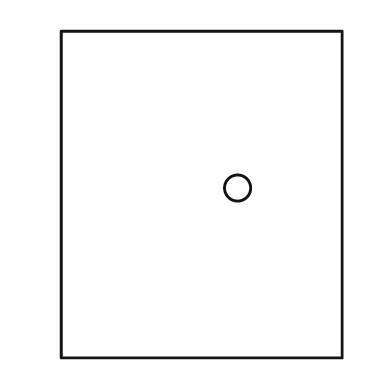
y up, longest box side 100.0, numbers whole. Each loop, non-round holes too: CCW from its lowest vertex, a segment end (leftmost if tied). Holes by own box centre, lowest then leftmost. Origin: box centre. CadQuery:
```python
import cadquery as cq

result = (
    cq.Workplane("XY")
    .moveTo(-43.0, -50.0)
    .lineTo(43.0, -50.0)
    .lineTo(43.0, 50.0)
    .lineTo(-43.0, 50.0)
    .close()
    .moveTo(11.0, 2.0)
    .circle(4.0)
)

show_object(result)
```